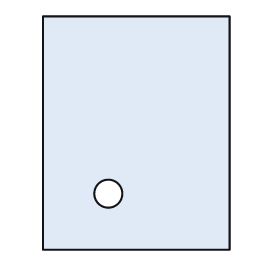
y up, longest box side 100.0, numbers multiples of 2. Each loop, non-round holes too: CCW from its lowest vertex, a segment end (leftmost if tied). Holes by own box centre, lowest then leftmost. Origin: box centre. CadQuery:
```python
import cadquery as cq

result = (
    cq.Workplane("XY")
    .moveTo(-40.0, -50.0)
    .lineTo(40.0, -50.0)
    .lineTo(40.0, 50.0)
    .lineTo(-40.0, 50.0)
    .close()
    .moveTo(-12.0, -26.0)
    .circle(6.0)
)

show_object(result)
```